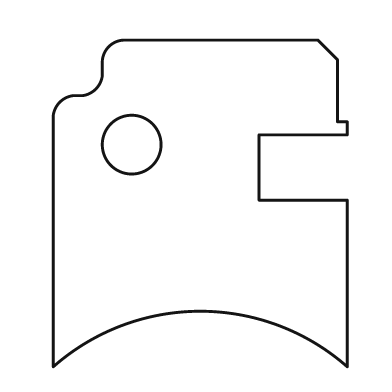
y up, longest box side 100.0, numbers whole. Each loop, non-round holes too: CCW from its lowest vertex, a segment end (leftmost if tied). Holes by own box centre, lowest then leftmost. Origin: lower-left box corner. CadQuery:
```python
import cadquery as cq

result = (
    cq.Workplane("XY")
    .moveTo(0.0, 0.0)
    .threePointArc((45.0, 17.0), (90.0, 0.0))
    .lineTo(90.0, 51.0)
    .lineTo(63.0, 51.0)
    .lineTo(63.0, 71.0)
    .lineTo(90.0, 71.0)
    .lineTo(90.0, 75.0)
    .lineTo(87.0, 75.0)
    .lineTo(87.0, 94.0)
    .lineTo(81.0, 100.0)
    .lineTo(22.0, 100.0)
    .threePointArc((17.0, 98.0), (15.0, 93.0))
    .lineTo(15.0, 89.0)
    .threePointArc((13.0, 85.0), (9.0, 83.0))
    .lineTo(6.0, 83.0)
    .threePointArc((2.0, 81.0), (0.0, 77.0))
    .close()
    .moveTo(24.0, 68.0)
    .circle(9.0)
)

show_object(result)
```